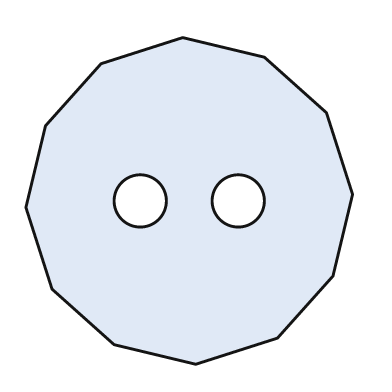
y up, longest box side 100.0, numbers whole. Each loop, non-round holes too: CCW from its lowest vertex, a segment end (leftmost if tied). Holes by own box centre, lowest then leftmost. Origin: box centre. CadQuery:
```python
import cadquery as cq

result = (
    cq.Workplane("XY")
    .moveTo(2.0, -50.0)
    .lineTo(27.0, -42.0)
    .lineTo(44.0, -23.0)
    .lineTo(50.0, 2.0)
    .lineTo(42.0, 27.0)
    .lineTo(23.0, 44.0)
    .lineTo(-2.0, 50.0)
    .lineTo(-27.0, 42.0)
    .lineTo(-44.0, 23.0)
    .lineTo(-50.0, -2.0)
    .lineTo(-42.0, -27.0)
    .lineTo(-23.0, -44.0)
    .close()
    .moveTo(-15.0, 0.0)
    .circle(8.0)
    .moveTo(15.0, 0.0)
    .circle(8.0)
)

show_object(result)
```